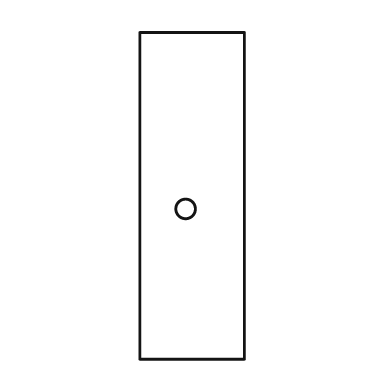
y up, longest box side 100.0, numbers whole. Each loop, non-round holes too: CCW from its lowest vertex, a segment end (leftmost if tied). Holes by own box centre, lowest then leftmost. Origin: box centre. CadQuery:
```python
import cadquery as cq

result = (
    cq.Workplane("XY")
    .moveTo(-16.0, -50.0)
    .lineTo(16.0, -50.0)
    .lineTo(16.0, 50.0)
    .lineTo(-16.0, 50.0)
    .close()
    .moveTo(-2.0, -4.0)
    .circle(3.0)
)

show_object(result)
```